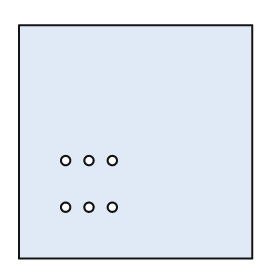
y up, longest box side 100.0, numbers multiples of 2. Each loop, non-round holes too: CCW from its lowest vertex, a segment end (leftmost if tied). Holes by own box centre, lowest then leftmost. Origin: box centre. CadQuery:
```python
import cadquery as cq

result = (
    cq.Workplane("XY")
    .moveTo(-50.0, -50.0)
    .lineTo(50.0, -50.0)
    .lineTo(50.0, 50.0)
    .lineTo(-50.0, 50.0)
    .close()
    .moveTo(-30.0, -28.0)
    .circle(2.0)
    .moveTo(-20.0, -28.0)
    .circle(2.0)
    .moveTo(-10.0, -28.0)
    .circle(2.0)
    .moveTo(-30.0, -8.0)
    .circle(2.0)
    .moveTo(-20.0, -8.0)
    .circle(2.0)
    .moveTo(-10.0, -8.0)
    .circle(2.0)
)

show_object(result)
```